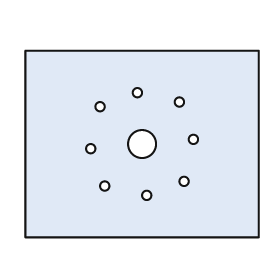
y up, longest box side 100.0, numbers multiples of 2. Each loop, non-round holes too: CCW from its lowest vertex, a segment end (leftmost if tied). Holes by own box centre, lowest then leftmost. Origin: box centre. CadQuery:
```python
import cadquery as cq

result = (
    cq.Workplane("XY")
    .moveTo(-50.0, -40.0)
    .lineTo(50.0, -40.0)
    .lineTo(50.0, 40.0)
    .lineTo(-50.0, 40.0)
    .close()
    .moveTo(2.0, -22.0)
    .circle(2.0)
    .moveTo(-16.0, -18.0)
    .circle(2.0)
    .moveTo(18.0, -16.0)
    .circle(2.0)
    .moveTo(-22.0, -2.0)
    .circle(2.0)
    .moveTo(0.0, 0.0)
    .circle(6.0)
    .moveTo(22.0, 2.0)
    .circle(2.0)
    .moveTo(-18.0, 16.0)
    .circle(2.0)
    .moveTo(16.0, 18.0)
    .circle(2.0)
    .moveTo(-2.0, 22.0)
    .circle(2.0)
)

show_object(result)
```